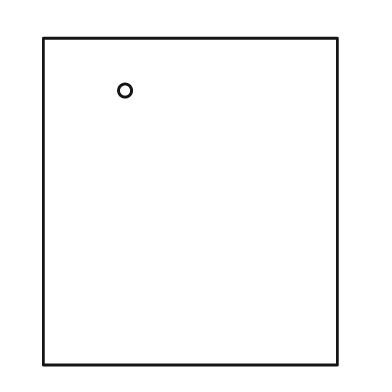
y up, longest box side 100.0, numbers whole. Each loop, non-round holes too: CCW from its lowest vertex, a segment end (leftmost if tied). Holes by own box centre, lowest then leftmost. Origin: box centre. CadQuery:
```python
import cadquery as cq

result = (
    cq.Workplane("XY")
    .moveTo(-45.0, -50.0)
    .lineTo(45.0, -50.0)
    .lineTo(45.0, 50.0)
    .lineTo(-45.0, 50.0)
    .close()
    .moveTo(-20.0, 34.0)
    .circle(2.0)
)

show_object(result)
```